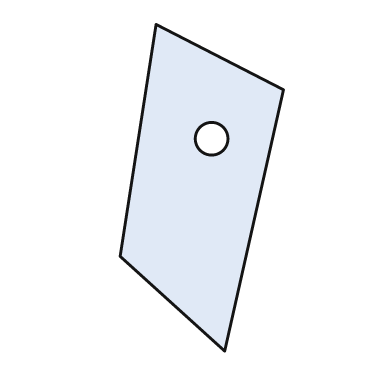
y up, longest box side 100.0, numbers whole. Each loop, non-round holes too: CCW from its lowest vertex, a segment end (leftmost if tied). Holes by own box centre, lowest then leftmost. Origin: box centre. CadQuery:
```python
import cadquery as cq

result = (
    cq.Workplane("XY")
    .moveTo(7.0, -50.0)
    .lineTo(25.0, 30.0)
    .lineTo(-14.0, 50.0)
    .lineTo(-25.0, -21.0)
    .close()
    .moveTo(3.0, 15.0)
    .circle(5.0)
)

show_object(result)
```